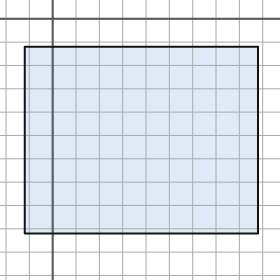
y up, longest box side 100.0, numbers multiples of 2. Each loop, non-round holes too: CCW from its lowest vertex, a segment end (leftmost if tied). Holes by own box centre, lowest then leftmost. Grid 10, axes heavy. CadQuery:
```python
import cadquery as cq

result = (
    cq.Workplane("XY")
    .moveTo(-12.0, -92.0)
    .lineTo(88.0, -92.0)
    .lineTo(88.0, -12.0)
    .lineTo(-12.0, -12.0)
    .close()
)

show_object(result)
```